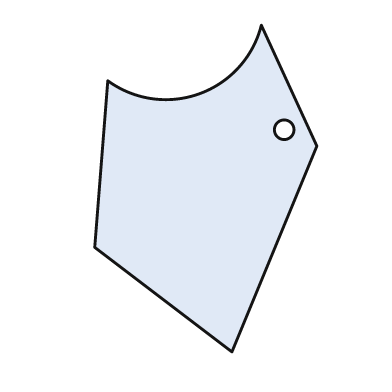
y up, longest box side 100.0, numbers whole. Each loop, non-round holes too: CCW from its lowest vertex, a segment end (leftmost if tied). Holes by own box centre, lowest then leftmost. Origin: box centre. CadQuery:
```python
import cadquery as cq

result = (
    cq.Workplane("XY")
    .moveTo(8.0, -50.0)
    .lineTo(34.0, 13.0)
    .lineTo(17.0, 50.0)
    .threePointArc((-2.0, 29.0), (-30.0, 33.0))
    .lineTo(-34.0, -18.0)
    .close()
    .moveTo(24.0, 18.0)
    .circle(3.0)
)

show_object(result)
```